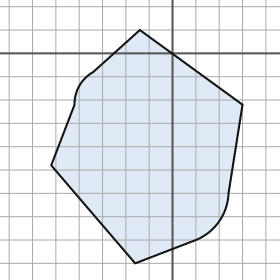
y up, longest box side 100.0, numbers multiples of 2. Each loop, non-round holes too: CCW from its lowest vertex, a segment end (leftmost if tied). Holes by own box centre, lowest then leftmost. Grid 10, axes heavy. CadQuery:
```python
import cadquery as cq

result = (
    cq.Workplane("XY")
    .moveTo(-16.0, -90.0)
    .lineTo(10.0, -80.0)
    .threePointArc((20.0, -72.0), (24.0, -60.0))
    .lineTo(30.0, -22.0)
    .lineTo(-14.0, 10.0)
    .lineTo(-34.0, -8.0)
    .threePointArc((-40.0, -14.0), (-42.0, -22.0))
    .lineTo(-52.0, -48.0)
    .close()
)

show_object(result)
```